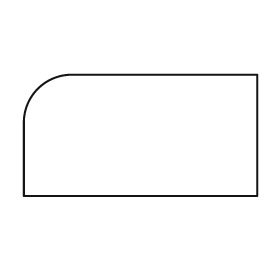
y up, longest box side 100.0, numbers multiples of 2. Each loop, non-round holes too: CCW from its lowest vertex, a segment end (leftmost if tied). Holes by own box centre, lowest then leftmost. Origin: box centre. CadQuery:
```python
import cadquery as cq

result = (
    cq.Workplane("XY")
    .moveTo(-50.0, -26.0)
    .lineTo(50.0, -26.0)
    .lineTo(50.0, 26.0)
    .lineTo(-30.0, 26.0)
    .threePointArc((-44.0, 20.0), (-50.0, 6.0))
    .close()
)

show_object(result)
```